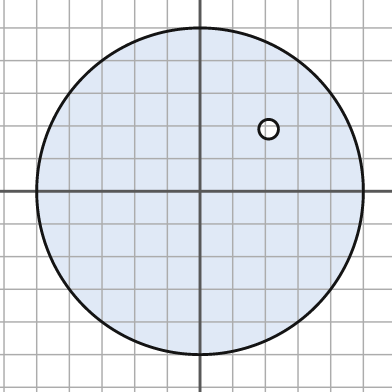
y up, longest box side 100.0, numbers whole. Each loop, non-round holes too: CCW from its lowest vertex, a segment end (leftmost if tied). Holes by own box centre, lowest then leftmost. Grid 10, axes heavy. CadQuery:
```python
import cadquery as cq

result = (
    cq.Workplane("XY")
    .moveTo(0.0, 0.0)
    .circle(50.0)
    .moveTo(21.0, 19.0)
    .circle(3.0)
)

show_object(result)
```